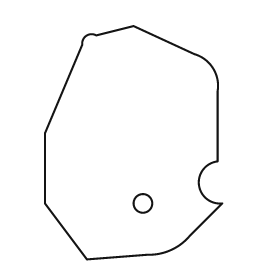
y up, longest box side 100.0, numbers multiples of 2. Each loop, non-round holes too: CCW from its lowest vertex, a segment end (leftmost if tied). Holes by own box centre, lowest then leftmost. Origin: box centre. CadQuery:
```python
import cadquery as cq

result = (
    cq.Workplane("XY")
    .moveTo(-20.0, -50.0)
    .lineTo(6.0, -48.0)
    .threePointArc((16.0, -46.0), (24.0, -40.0))
    .lineTo(38.0, -26.0)
    .threePointArc((28.0, -18.0), (36.0, -8.0))
    .lineTo(36.0, 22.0)
    .threePointArc((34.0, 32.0), (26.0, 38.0))
    .lineTo(0.0, 50.0)
    .lineTo(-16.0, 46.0)
    .threePointArc((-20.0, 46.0), (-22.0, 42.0))
    .lineTo(-38.0, 4.0)
    .lineTo(-38.0, -26.0)
    .close()
    .moveTo(4.0, -26.0)
    .circle(4.0)
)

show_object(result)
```